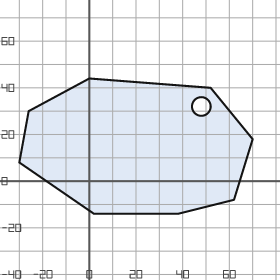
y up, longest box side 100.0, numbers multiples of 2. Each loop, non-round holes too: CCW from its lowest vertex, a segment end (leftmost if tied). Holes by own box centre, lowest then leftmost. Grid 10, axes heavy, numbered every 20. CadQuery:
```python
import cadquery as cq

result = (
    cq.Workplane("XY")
    .moveTo(2.0, -14.0)
    .lineTo(38.0, -14.0)
    .lineTo(62.0, -8.0)
    .lineTo(70.0, 18.0)
    .lineTo(52.0, 40.0)
    .lineTo(0.0, 44.0)
    .lineTo(-26.0, 30.0)
    .lineTo(-30.0, 8.0)
    .close()
    .moveTo(48.0, 32.0)
    .circle(4.0)
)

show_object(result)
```